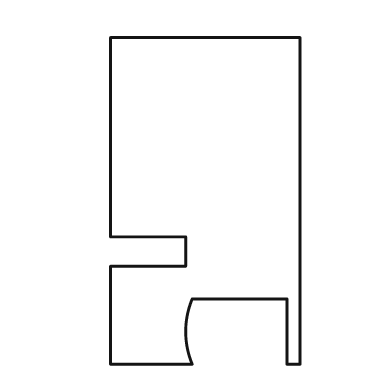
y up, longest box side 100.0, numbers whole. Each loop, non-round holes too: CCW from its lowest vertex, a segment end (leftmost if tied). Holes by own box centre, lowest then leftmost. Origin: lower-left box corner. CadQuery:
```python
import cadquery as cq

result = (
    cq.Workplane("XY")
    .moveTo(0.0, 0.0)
    .lineTo(25.0, 0.0)
    .threePointArc((23.0, 10.0), (25.0, 20.0))
    .lineTo(54.0, 20.0)
    .lineTo(54.0, 0.0)
    .lineTo(58.0, 0.0)
    .lineTo(58.0, 100.0)
    .lineTo(0.0, 100.0)
    .lineTo(0.0, 39.0)
    .lineTo(23.0, 39.0)
    .lineTo(23.0, 30.0)
    .lineTo(0.0, 30.0)
    .close()
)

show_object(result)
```